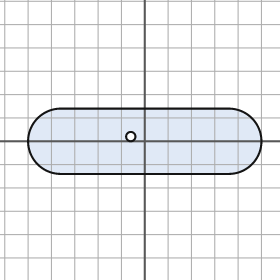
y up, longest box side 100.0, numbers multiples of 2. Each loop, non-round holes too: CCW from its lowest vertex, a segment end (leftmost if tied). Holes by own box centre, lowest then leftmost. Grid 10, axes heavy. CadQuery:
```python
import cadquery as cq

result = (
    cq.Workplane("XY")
    .moveTo(-36.0, -14.0)
    .lineTo(36.0, -14.0)
    .threePointArc((50.0, 0.0), (36.0, 14.0))
    .lineTo(-36.0, 14.0)
    .threePointArc((-50.0, 0.0), (-36.0, -14.0))
    .close()
    .moveTo(-6.0, 2.0)
    .circle(2.0)
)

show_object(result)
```